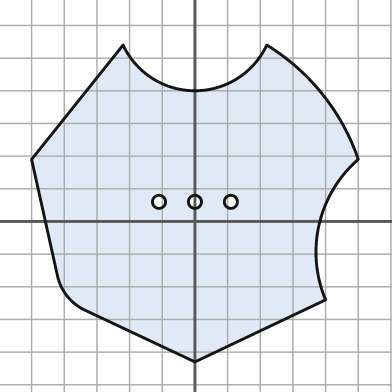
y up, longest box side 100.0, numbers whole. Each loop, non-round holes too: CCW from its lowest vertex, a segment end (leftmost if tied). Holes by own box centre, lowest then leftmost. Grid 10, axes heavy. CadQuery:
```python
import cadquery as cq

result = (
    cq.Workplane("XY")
    .moveTo(0.0, -43.0)
    .lineTo(40.0, -24.0)
    .threePointArc((38.0, -1.0), (50.0, 19.0))
    .threePointArc((39.0, 39.0), (22.0, 54.0))
    .threePointArc((0.0, 40.0), (-22.0, 54.0))
    .lineTo(-50.0, 19.0)
    .lineTo(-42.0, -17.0)
    .threePointArc((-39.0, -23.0), (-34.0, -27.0))
    .close()
    .moveTo(-11.0, 6.0)
    .circle(2.0)
    .moveTo(0.0, 6.0)
    .circle(2.0)
    .moveTo(11.0, 6.0)
    .circle(2.0)
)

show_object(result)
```